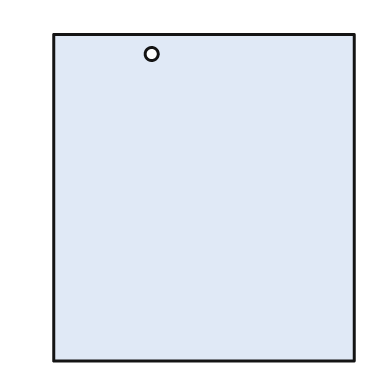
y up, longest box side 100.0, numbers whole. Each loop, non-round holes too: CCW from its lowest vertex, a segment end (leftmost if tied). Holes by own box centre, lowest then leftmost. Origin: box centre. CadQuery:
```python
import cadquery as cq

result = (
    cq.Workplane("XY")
    .moveTo(-46.0, -50.0)
    .lineTo(46.0, -50.0)
    .lineTo(46.0, 50.0)
    .lineTo(-46.0, 50.0)
    .close()
    .moveTo(-16.0, 44.0)
    .circle(2.0)
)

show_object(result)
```